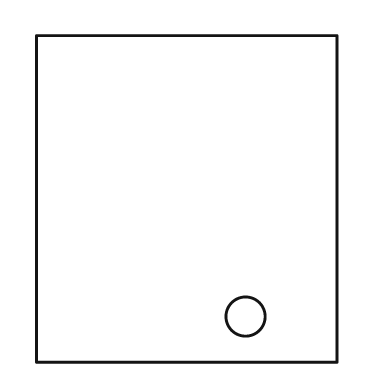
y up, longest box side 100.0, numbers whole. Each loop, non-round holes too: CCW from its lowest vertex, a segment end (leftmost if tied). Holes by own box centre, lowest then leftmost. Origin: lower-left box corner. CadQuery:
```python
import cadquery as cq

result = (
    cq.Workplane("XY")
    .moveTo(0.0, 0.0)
    .lineTo(92.0, 0.0)
    .lineTo(92.0, 100.0)
    .lineTo(0.0, 100.0)
    .close()
    .moveTo(64.0, 14.0)
    .circle(6.0)
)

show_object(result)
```